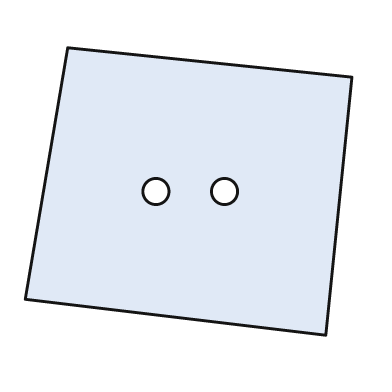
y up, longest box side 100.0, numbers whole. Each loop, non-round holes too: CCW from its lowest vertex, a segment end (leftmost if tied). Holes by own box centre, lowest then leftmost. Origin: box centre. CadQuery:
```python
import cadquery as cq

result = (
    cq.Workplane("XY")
    .moveTo(42.0, -44.0)
    .lineTo(50.0, 35.0)
    .lineTo(-37.0, 44.0)
    .lineTo(-50.0, -33.0)
    .close()
    .moveTo(-10.0, 0.0)
    .circle(4.0)
    .moveTo(11.0, 0.0)
    .circle(4.0)
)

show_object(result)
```